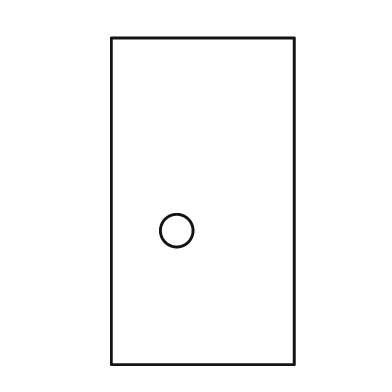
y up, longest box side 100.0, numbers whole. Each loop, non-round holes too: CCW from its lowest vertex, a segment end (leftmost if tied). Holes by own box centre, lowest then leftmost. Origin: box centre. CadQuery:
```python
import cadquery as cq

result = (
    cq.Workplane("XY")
    .moveTo(-28.0, -50.0)
    .lineTo(28.0, -50.0)
    .lineTo(28.0, 50.0)
    .lineTo(-28.0, 50.0)
    .close()
    .moveTo(-8.0, -9.0)
    .circle(5.0)
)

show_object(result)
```